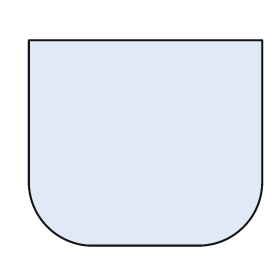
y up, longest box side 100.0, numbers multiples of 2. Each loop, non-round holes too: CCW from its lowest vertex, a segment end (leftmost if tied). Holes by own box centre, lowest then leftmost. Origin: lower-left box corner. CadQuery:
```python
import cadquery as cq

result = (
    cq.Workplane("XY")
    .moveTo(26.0, 0.0)
    .lineTo(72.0, 0.0)
    .threePointArc((92.0, 8.0), (100.0, 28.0))
    .lineTo(100.0, 88.0)
    .lineTo(0.0, 88.0)
    .lineTo(0.0, 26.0)
    .threePointArc((8.0, 8.0), (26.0, 0.0))
    .close()
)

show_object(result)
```